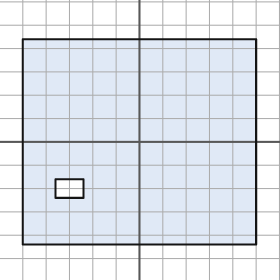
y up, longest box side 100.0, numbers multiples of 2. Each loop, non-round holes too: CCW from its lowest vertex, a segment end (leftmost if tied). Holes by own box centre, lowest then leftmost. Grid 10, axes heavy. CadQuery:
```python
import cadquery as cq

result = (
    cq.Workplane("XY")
    .moveTo(-50.0, -44.0)
    .lineTo(50.0, -44.0)
    .lineTo(50.0, 44.0)
    .lineTo(-50.0, 44.0)
    .close()
    .moveTo(-36.0, -24.0)
    .lineTo(-24.0, -24.0)
    .lineTo(-24.0, -16.0)
    .lineTo(-36.0, -16.0)
    .close()
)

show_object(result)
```